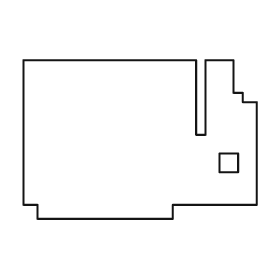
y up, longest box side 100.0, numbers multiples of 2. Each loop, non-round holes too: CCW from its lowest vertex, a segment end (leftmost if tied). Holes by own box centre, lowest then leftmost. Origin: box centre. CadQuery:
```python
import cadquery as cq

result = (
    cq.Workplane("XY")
    .moveTo(-44.0, -34.0)
    .lineTo(14.0, -34.0)
    .lineTo(14.0, -28.0)
    .lineTo(50.0, -28.0)
    .lineTo(50.0, 16.0)
    .lineTo(44.0, 16.0)
    .lineTo(44.0, 20.0)
    .lineTo(40.0, 20.0)
    .lineTo(40.0, 34.0)
    .lineTo(28.0, 34.0)
    .lineTo(28.0, 2.0)
    .lineTo(24.0, 2.0)
    .lineTo(24.0, 34.0)
    .lineTo(-50.0, 34.0)
    .lineTo(-50.0, -28.0)
    .lineTo(-44.0, -28.0)
    .close()
    .moveTo(34.0, -14.0)
    .lineTo(42.0, -14.0)
    .lineTo(42.0, -6.0)
    .lineTo(34.0, -6.0)
    .close()
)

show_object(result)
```